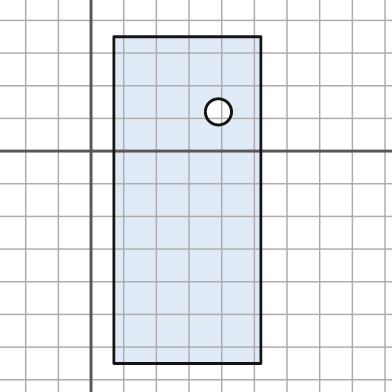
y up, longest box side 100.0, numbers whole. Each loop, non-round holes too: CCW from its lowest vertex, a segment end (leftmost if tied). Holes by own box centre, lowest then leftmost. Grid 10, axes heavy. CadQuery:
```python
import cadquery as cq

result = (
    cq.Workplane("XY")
    .moveTo(7.0, -65.0)
    .lineTo(52.0, -65.0)
    .lineTo(52.0, 35.0)
    .lineTo(7.0, 35.0)
    .close()
    .moveTo(39.0, 12.0)
    .circle(4.0)
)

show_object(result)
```